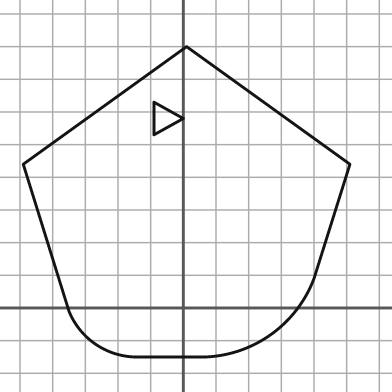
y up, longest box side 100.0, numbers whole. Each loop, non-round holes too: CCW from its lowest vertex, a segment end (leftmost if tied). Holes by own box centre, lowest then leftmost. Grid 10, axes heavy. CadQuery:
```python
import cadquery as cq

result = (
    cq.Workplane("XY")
    .moveTo(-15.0, -15.0)
    .lineTo(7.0, -15.0)
    .threePointArc((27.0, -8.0), (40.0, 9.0))
    .lineTo(51.0, 44.0)
    .lineTo(1.0, 80.0)
    .lineTo(-49.0, 44.0)
    .lineTo(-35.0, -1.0)
    .threePointArc((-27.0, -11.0), (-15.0, -15.0))
    .close()
    .moveTo(-9.0, 53.0)
    .lineTo(0.0, 58.0)
    .lineTo(-9.0, 63.0)
    .close()
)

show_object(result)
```